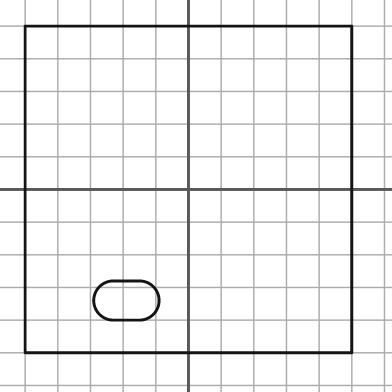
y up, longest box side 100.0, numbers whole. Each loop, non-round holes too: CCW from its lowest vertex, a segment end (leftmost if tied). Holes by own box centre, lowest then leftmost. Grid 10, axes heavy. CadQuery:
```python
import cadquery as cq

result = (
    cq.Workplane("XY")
    .moveTo(-50.0, -50.0)
    .lineTo(50.0, -50.0)
    .lineTo(50.0, 50.0)
    .lineTo(-50.0, 50.0)
    .close()
    .moveTo(-23.0, -40.0)
    .lineTo(-15.0, -40.0)
    .threePointArc((-9.0, -34.0), (-15.0, -28.0))
    .lineTo(-23.0, -28.0)
    .threePointArc((-29.0, -34.0), (-23.0, -40.0))
    .close()
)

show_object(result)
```